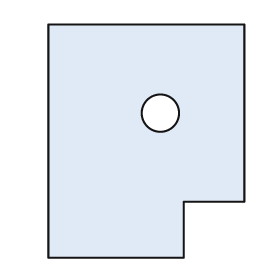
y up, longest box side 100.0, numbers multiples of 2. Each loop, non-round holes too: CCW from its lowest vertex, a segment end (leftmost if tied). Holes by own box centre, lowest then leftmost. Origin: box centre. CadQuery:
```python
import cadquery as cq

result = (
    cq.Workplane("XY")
    .moveTo(-42.0, -50.0)
    .lineTo(16.0, -50.0)
    .lineTo(16.0, -26.0)
    .lineTo(42.0, -26.0)
    .lineTo(42.0, 50.0)
    .lineTo(-42.0, 50.0)
    .close()
    .moveTo(6.0, 12.0)
    .circle(8.0)
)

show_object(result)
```